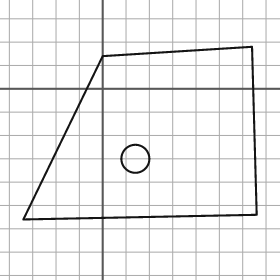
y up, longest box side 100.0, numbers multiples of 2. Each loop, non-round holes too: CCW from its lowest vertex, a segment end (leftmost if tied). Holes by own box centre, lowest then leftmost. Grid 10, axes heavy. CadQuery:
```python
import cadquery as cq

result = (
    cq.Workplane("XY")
    .moveTo(-34.0, -56.0)
    .lineTo(66.0, -54.0)
    .lineTo(64.0, 18.0)
    .lineTo(0.0, 14.0)
    .close()
    .moveTo(14.0, -30.0)
    .circle(6.0)
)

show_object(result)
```